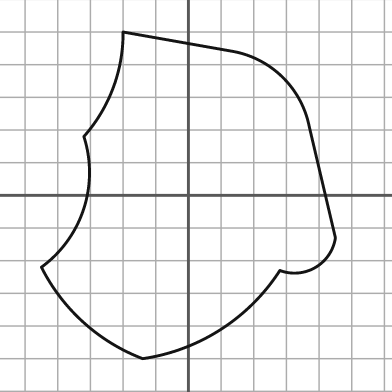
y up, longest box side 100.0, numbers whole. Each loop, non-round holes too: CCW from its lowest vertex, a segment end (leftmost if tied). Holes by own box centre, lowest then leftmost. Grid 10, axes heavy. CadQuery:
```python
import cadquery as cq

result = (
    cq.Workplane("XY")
    .moveTo(-14.0, -50.0)
    .threePointArc((10.0, -41.0), (28.0, -23.0))
    .threePointArc((39.0, -22.0), (45.0, -13.0))
    .lineTo(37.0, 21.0)
    .threePointArc((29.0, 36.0), (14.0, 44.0))
    .lineTo(-20.0, 50.0)
    .threePointArc((-23.0, 33.0), (-32.0, 18.0))
    .threePointArc((-32.0, -4.0), (-45.0, -22.0))
    .threePointArc((-32.0, -39.0), (-14.0, -50.0))
    .close()
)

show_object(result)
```